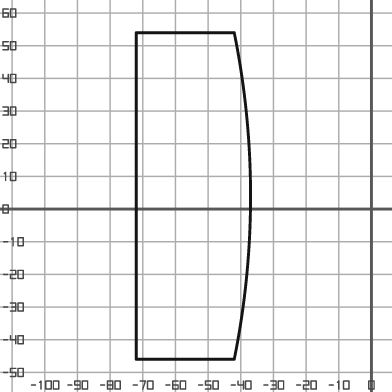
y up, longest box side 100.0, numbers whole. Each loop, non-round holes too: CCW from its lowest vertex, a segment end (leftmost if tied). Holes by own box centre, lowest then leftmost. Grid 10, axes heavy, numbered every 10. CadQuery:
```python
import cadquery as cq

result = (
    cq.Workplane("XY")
    .moveTo(-72.0, -46.0)
    .lineTo(-42.0, -46.0)
    .threePointArc((-37.0, 4.0), (-42.0, 54.0))
    .lineTo(-72.0, 54.0)
    .close()
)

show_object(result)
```